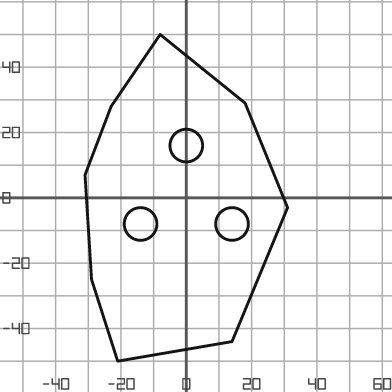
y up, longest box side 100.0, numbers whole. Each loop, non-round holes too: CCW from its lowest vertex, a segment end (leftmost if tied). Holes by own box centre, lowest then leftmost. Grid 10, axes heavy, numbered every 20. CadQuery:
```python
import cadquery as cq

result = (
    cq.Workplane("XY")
    .moveTo(-21.0, -50.0)
    .lineTo(14.0, -44.0)
    .lineTo(31.0, -3.0)
    .lineTo(18.0, 29.0)
    .lineTo(-8.0, 50.0)
    .lineTo(-23.0, 28.0)
    .lineTo(-31.0, 7.0)
    .lineTo(-29.0, -25.0)
    .close()
    .moveTo(-14.0, -8.0)
    .circle(5.0)
    .moveTo(14.0, -8.0)
    .circle(5.0)
    .moveTo(0.0, 16.0)
    .circle(5.0)
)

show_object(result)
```